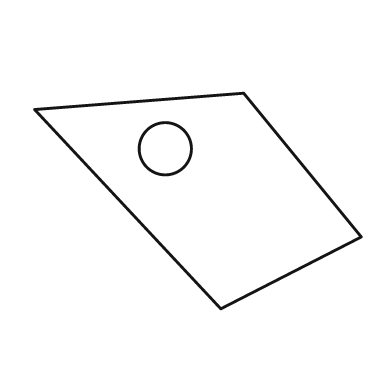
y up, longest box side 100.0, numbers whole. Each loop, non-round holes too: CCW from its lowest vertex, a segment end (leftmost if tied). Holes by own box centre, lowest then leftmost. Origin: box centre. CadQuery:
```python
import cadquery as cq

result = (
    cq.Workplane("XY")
    .moveTo(7.0, -33.0)
    .lineTo(50.0, -11.0)
    .lineTo(14.0, 33.0)
    .lineTo(-50.0, 28.0)
    .close()
    .moveTo(-10.0, 16.0)
    .circle(8.0)
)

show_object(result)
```